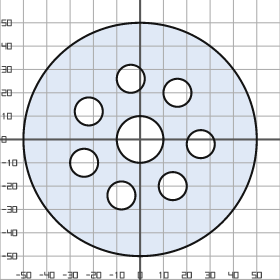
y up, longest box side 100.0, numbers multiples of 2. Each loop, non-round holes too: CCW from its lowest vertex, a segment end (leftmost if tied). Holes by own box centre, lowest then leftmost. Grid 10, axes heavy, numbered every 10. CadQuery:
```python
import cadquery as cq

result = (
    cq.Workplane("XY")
    .moveTo(0.0, 0.0)
    .circle(50.0)
    .moveTo(-8.0, -24.0)
    .circle(6.0)
    .moveTo(14.0, -20.0)
    .circle(6.0)
    .moveTo(-24.0, -10.0)
    .circle(6.0)
    .moveTo(26.0, -2.0)
    .circle(6.0)
    .moveTo(0.0, 0.0)
    .circle(10.0)
    .moveTo(-22.0, 12.0)
    .circle(6.0)
    .moveTo(16.0, 20.0)
    .circle(6.0)
    .moveTo(-4.0, 26.0)
    .circle(6.0)
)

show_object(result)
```